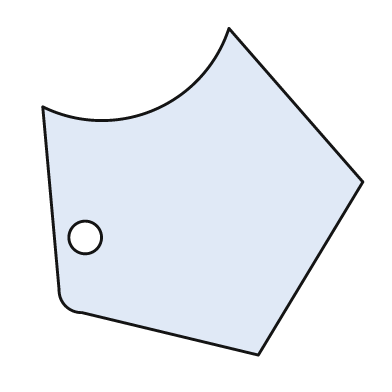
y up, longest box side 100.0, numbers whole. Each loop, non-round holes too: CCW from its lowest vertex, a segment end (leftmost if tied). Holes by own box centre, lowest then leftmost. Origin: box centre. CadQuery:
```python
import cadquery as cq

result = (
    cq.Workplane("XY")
    .moveTo(17.0, -50.0)
    .lineTo(49.0, 3.0)
    .lineTo(8.0, 50.0)
    .threePointArc((-15.0, 25.0), (-49.0, 26.0))
    .lineTo(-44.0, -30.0)
    .threePointArc((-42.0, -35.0), (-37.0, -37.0))
    .close()
    .moveTo(-36.0, -14.0)
    .circle(5.0)
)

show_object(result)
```